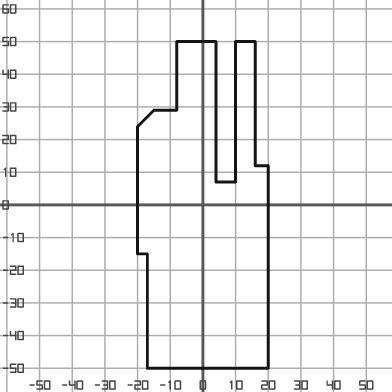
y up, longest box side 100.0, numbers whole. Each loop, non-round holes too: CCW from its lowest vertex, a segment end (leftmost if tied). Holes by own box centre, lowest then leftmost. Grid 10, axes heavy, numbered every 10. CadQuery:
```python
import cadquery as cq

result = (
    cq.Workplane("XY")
    .moveTo(-17.0, -50.0)
    .lineTo(20.0, -50.0)
    .lineTo(20.0, 12.0)
    .lineTo(16.0, 12.0)
    .lineTo(16.0, 50.0)
    .lineTo(10.0, 50.0)
    .lineTo(10.0, 7.0)
    .lineTo(4.0, 7.0)
    .lineTo(4.0, 50.0)
    .lineTo(-8.0, 50.0)
    .lineTo(-8.0, 29.0)
    .lineTo(-15.0, 29.0)
    .lineTo(-20.0, 24.0)
    .lineTo(-20.0, -15.0)
    .lineTo(-17.0, -15.0)
    .close()
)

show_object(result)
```